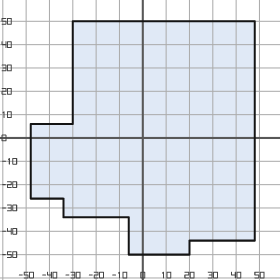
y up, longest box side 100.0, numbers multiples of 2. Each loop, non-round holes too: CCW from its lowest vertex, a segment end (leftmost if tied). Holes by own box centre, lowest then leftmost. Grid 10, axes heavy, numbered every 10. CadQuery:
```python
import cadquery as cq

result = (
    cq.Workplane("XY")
    .moveTo(-6.0, -50.0)
    .lineTo(20.0, -50.0)
    .lineTo(20.0, -44.0)
    .lineTo(48.0, -44.0)
    .lineTo(48.0, 50.0)
    .lineTo(-30.0, 50.0)
    .lineTo(-30.0, 6.0)
    .lineTo(-48.0, 6.0)
    .lineTo(-48.0, -26.0)
    .lineTo(-34.0, -26.0)
    .lineTo(-34.0, -34.0)
    .lineTo(-6.0, -34.0)
    .close()
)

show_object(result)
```